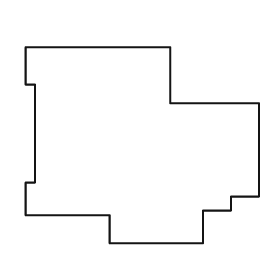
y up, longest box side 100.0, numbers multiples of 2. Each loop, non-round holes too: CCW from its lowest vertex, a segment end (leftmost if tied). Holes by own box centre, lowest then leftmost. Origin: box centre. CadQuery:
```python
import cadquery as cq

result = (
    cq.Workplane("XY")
    .moveTo(-14.0, -42.0)
    .lineTo(26.0, -42.0)
    .lineTo(26.0, -28.0)
    .lineTo(38.0, -28.0)
    .lineTo(38.0, -22.0)
    .lineTo(50.0, -22.0)
    .lineTo(50.0, 18.0)
    .lineTo(12.0, 18.0)
    .lineTo(12.0, 42.0)
    .lineTo(-50.0, 42.0)
    .lineTo(-50.0, 26.0)
    .lineTo(-46.0, 26.0)
    .lineTo(-46.0, -16.0)
    .lineTo(-50.0, -16.0)
    .lineTo(-50.0, -30.0)
    .lineTo(-14.0, -30.0)
    .close()
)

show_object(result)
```